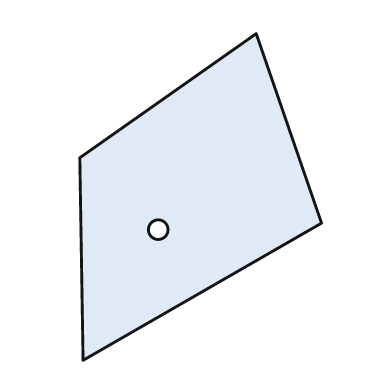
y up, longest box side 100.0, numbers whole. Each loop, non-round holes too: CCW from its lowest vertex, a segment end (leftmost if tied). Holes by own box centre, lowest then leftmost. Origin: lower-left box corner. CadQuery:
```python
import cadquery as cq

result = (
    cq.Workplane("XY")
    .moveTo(1.0, 0.0)
    .lineTo(74.0, 42.0)
    .lineTo(54.0, 100.0)
    .lineTo(0.0, 62.0)
    .close()
    .moveTo(24.0, 40.0)
    .circle(3.0)
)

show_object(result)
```